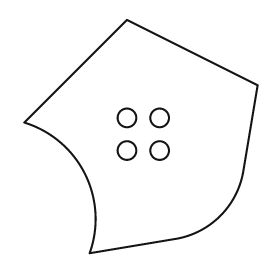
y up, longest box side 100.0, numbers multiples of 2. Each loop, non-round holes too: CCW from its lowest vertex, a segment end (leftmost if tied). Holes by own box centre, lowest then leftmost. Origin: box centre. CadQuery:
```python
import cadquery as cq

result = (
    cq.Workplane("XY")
    .moveTo(-22.0, -50.0)
    .lineTo(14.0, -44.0)
    .threePointArc((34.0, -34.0), (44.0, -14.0))
    .lineTo(50.0, 22.0)
    .lineTo(-6.0, 50.0)
    .lineTo(-50.0, 6.0)
    .threePointArc((-24.0, -16.0), (-22.0, -50.0))
    .close()
    .moveTo(-6.0, -6.0)
    .circle(4.0)
    .moveTo(8.0, -6.0)
    .circle(4.0)
    .moveTo(-6.0, 8.0)
    .circle(4.0)
    .moveTo(8.0, 8.0)
    .circle(4.0)
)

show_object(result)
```